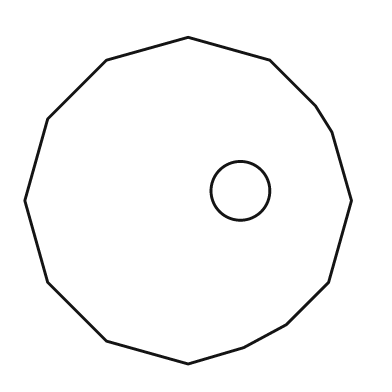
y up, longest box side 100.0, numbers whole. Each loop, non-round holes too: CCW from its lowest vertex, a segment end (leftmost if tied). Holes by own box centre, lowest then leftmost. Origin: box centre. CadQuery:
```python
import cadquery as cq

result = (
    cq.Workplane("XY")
    .moveTo(0.0, -50.0)
    .lineTo(17.0, -45.0)
    .lineTo(30.0, -38.0)
    .lineTo(43.0, -25.0)
    .lineTo(50.0, 0.0)
    .lineTo(44.0, 21.0)
    .lineTo(39.0, 29.0)
    .lineTo(25.0, 43.0)
    .lineTo(0.0, 50.0)
    .lineTo(-25.0, 43.0)
    .lineTo(-43.0, 25.0)
    .lineTo(-50.0, 0.0)
    .lineTo(-43.0, -25.0)
    .lineTo(-25.0, -43.0)
    .close()
    .moveTo(16.0, 3.0)
    .circle(9.0)
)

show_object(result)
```